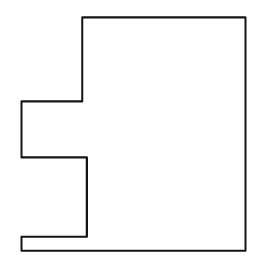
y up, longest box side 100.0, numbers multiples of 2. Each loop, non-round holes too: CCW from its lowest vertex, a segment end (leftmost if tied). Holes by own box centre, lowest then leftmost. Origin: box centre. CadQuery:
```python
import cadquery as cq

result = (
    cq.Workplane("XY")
    .moveTo(-48.0, -50.0)
    .lineTo(48.0, -50.0)
    .lineTo(48.0, 50.0)
    .lineTo(-22.0, 50.0)
    .lineTo(-22.0, 14.0)
    .lineTo(-48.0, 14.0)
    .lineTo(-48.0, -10.0)
    .lineTo(-20.0, -10.0)
    .lineTo(-20.0, -44.0)
    .lineTo(-48.0, -44.0)
    .close()
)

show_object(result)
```